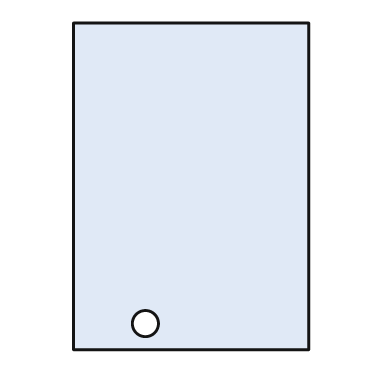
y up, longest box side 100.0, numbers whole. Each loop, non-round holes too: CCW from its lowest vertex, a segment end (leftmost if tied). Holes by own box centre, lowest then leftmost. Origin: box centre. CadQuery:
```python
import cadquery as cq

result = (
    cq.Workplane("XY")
    .moveTo(-36.0, -50.0)
    .lineTo(36.0, -50.0)
    .lineTo(36.0, 50.0)
    .lineTo(-36.0, 50.0)
    .close()
    .moveTo(-14.0, -42.0)
    .circle(4.0)
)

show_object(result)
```